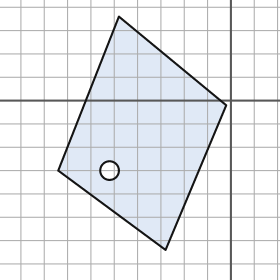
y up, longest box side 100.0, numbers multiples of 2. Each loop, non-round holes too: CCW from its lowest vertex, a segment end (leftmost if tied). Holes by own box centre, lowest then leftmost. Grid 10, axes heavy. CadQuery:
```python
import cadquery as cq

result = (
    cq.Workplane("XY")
    .moveTo(-28.0, -64.0)
    .lineTo(-2.0, -2.0)
    .lineTo(-48.0, 36.0)
    .lineTo(-74.0, -30.0)
    .close()
    .moveTo(-52.0, -30.0)
    .circle(4.0)
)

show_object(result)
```